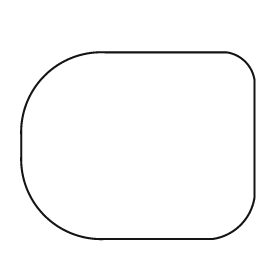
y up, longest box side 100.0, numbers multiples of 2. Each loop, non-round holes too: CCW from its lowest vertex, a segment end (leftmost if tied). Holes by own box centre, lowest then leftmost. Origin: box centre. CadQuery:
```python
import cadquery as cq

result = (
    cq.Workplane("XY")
    .moveTo(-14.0, -40.0)
    .lineTo(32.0, -40.0)
    .threePointArc((44.0, -34.0), (50.0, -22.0))
    .lineTo(50.0, 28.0)
    .threePointArc((46.0, 36.0), (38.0, 40.0))
    .lineTo(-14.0, 40.0)
    .threePointArc((-40.0, 30.0), (-50.0, 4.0))
    .lineTo(-50.0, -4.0)
    .threePointArc((-40.0, -30.0), (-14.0, -40.0))
    .close()
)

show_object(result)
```